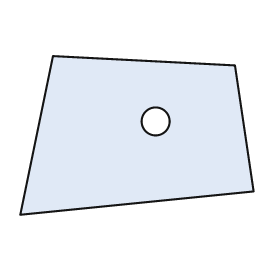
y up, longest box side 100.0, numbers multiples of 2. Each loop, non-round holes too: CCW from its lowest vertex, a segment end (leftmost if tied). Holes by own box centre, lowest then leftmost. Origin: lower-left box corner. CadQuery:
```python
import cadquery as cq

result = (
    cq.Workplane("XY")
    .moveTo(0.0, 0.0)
    .lineTo(100.0, 10.0)
    .lineTo(92.0, 64.0)
    .lineTo(14.0, 68.0)
    .close()
    .moveTo(58.0, 40.0)
    .circle(6.0)
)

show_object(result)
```